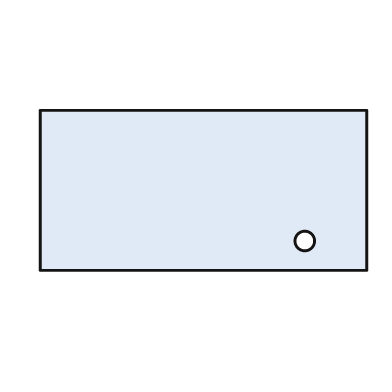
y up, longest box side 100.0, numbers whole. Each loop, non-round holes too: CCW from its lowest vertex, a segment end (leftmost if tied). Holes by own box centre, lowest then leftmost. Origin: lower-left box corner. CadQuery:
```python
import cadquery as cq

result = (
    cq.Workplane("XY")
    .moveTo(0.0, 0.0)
    .lineTo(100.0, 0.0)
    .lineTo(100.0, 49.0)
    .lineTo(0.0, 49.0)
    .close()
    .moveTo(81.0, 9.0)
    .circle(3.0)
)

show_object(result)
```